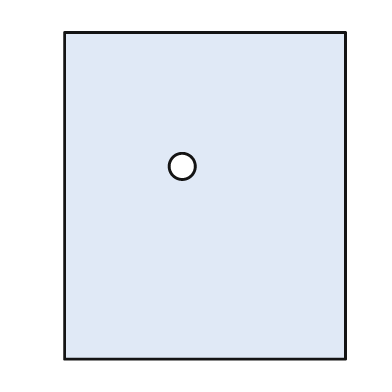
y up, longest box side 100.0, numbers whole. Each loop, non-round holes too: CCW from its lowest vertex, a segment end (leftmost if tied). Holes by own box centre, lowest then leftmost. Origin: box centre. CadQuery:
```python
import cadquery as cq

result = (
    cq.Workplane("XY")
    .moveTo(-43.0, -50.0)
    .lineTo(43.0, -50.0)
    .lineTo(43.0, 50.0)
    .lineTo(-43.0, 50.0)
    .close()
    .moveTo(-7.0, 9.0)
    .circle(4.0)
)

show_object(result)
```